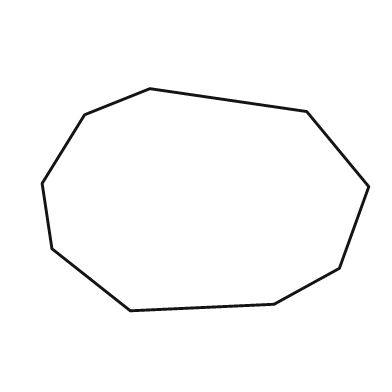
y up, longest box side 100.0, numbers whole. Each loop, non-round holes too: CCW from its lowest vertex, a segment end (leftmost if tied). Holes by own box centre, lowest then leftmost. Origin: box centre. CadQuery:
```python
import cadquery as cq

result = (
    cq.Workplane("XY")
    .moveTo(-23.0, -34.0)
    .lineTo(21.0, -32.0)
    .lineTo(41.0, -21.0)
    .lineTo(50.0, 4.0)
    .lineTo(31.0, 27.0)
    .lineTo(-17.0, 34.0)
    .lineTo(-37.0, 26.0)
    .lineTo(-50.0, 5.0)
    .lineTo(-47.0, -15.0)
    .close()
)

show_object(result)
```